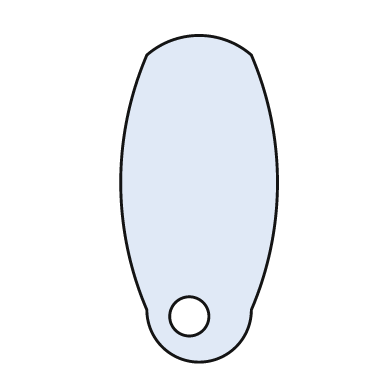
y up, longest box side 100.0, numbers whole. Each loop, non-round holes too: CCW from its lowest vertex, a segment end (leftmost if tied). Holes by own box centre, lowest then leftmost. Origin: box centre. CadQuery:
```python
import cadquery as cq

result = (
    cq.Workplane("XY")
    .moveTo(-16.0, -34.0)
    .threePointArc((0.0, -50.0), (16.0, -34.0))
    .threePointArc((24.0, 5.0), (16.0, 44.0))
    .threePointArc((0.0, 50.0), (-16.0, 44.0))
    .threePointArc((-24.0, 5.0), (-16.0, -34.0))
    .close()
    .moveTo(-3.0, -36.0)
    .circle(6.0)
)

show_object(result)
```